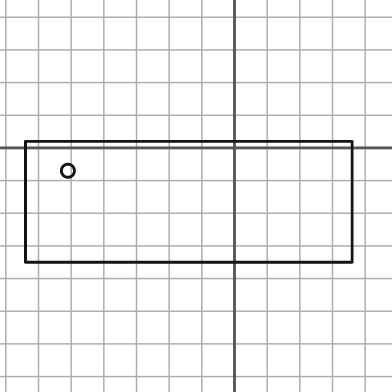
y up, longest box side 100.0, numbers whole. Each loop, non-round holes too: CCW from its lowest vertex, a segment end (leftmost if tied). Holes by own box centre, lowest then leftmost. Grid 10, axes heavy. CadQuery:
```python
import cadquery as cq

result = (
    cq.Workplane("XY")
    .moveTo(-64.0, -35.0)
    .lineTo(36.0, -35.0)
    .lineTo(36.0, 2.0)
    .lineTo(-64.0, 2.0)
    .close()
    .moveTo(-51.0, -7.0)
    .circle(2.0)
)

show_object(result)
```